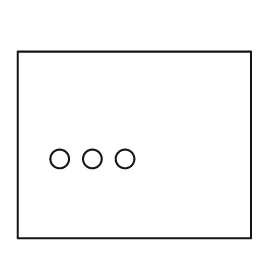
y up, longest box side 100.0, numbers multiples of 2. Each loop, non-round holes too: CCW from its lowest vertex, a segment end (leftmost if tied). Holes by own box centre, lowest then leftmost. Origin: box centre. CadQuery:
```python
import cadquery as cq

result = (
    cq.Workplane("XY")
    .moveTo(-50.0, -40.0)
    .lineTo(50.0, -40.0)
    .lineTo(50.0, 40.0)
    .lineTo(-50.0, 40.0)
    .close()
    .moveTo(-32.0, -6.0)
    .circle(4.0)
    .moveTo(-18.0, -6.0)
    .circle(4.0)
    .moveTo(-4.0, -6.0)
    .circle(4.0)
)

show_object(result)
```